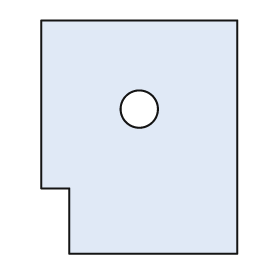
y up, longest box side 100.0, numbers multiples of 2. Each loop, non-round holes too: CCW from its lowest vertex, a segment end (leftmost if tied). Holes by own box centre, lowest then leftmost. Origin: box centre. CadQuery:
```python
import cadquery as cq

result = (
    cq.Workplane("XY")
    .moveTo(-30.0, -50.0)
    .lineTo(42.0, -50.0)
    .lineTo(42.0, 50.0)
    .lineTo(-42.0, 50.0)
    .lineTo(-42.0, -22.0)
    .lineTo(-30.0, -22.0)
    .close()
    .moveTo(0.0, 12.0)
    .circle(8.0)
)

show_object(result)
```